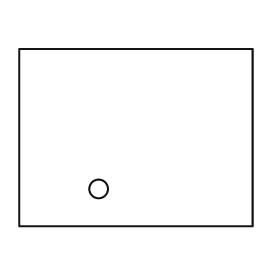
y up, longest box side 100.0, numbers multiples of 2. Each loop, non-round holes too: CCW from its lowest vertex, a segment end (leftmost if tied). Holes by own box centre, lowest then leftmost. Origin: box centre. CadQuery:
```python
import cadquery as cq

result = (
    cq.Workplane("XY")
    .moveTo(-50.0, -38.0)
    .lineTo(50.0, -38.0)
    .lineTo(50.0, 38.0)
    .lineTo(-50.0, 38.0)
    .close()
    .moveTo(-16.0, -22.0)
    .circle(4.0)
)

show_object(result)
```